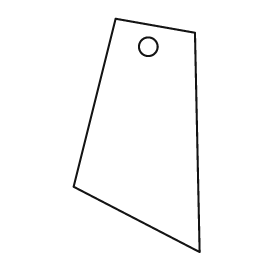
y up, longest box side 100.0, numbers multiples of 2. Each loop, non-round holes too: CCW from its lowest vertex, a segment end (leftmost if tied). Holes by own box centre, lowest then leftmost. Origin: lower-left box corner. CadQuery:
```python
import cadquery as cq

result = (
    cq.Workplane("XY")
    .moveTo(54.0, 0.0)
    .lineTo(52.0, 94.0)
    .lineTo(18.0, 100.0)
    .lineTo(0.0, 28.0)
    .close()
    .moveTo(32.0, 88.0)
    .circle(4.0)
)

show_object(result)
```